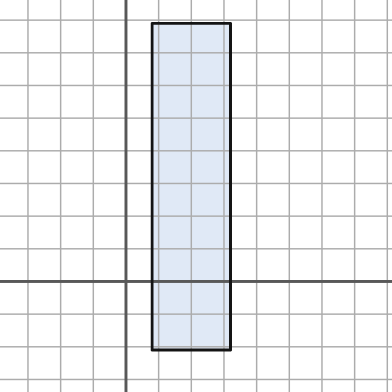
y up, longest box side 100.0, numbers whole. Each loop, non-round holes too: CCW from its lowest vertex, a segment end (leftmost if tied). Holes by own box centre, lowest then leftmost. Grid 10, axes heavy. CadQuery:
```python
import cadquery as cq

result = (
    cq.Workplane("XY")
    .moveTo(8.0, -21.0)
    .lineTo(32.0, -21.0)
    .lineTo(32.0, 79.0)
    .lineTo(8.0, 79.0)
    .close()
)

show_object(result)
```